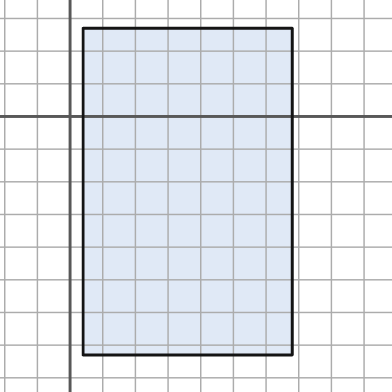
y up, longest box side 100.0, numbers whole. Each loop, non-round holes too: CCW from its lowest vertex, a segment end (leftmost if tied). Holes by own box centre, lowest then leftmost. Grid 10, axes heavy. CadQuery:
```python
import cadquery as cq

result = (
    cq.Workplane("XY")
    .moveTo(4.0, -73.0)
    .lineTo(68.0, -73.0)
    .lineTo(68.0, 27.0)
    .lineTo(4.0, 27.0)
    .close()
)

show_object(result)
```